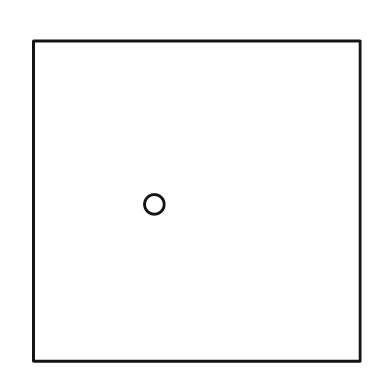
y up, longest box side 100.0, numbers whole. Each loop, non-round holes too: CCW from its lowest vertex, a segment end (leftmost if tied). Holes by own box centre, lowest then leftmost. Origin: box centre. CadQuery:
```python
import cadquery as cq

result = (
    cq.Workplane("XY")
    .moveTo(-50.0, -49.0)
    .lineTo(50.0, -49.0)
    .lineTo(50.0, 49.0)
    .lineTo(-50.0, 49.0)
    .close()
    .moveTo(-13.0, -1.0)
    .circle(3.0)
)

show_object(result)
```